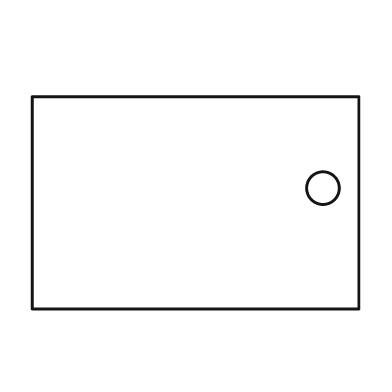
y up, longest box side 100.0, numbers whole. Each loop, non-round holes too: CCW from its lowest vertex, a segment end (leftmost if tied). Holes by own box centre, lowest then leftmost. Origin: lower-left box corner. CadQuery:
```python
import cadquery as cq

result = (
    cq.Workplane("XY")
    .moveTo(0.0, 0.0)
    .lineTo(100.0, 0.0)
    .lineTo(100.0, 65.0)
    .lineTo(0.0, 65.0)
    .close()
    .moveTo(89.0, 37.0)
    .circle(5.0)
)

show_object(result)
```